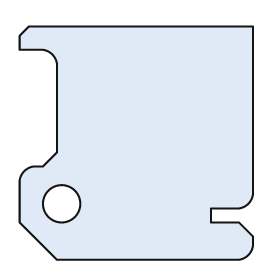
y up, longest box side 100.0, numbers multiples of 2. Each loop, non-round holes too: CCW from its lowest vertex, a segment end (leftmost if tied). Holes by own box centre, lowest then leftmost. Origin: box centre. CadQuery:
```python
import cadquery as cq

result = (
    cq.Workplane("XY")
    .moveTo(-34.0, -50.0)
    .lineTo(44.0, -50.0)
    .threePointArc((48.0, -48.0), (50.0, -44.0))
    .lineTo(50.0, -40.0)
    .lineTo(44.0, -34.0)
    .lineTo(32.0, -34.0)
    .lineTo(32.0, -28.0)
    .lineTo(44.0, -28.0)
    .threePointArc((48.0, -26.0), (50.0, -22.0))
    .lineTo(50.0, 50.0)
    .lineTo(-46.0, 50.0)
    .lineTo(-50.0, 46.0)
    .lineTo(-50.0, 40.0)
    .lineTo(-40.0, 40.0)
    .threePointArc((-36.0, 38.0), (-34.0, 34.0))
    .lineTo(-34.0, -4.0)
    .lineTo(-40.0, -10.0)
    .lineTo(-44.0, -10.0)
    .threePointArc((-48.0, -12.0), (-50.0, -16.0))
    .lineTo(-50.0, -34.0)
    .close()
    .moveTo(-32.0, -26.0)
    .circle(8.0)
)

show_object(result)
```